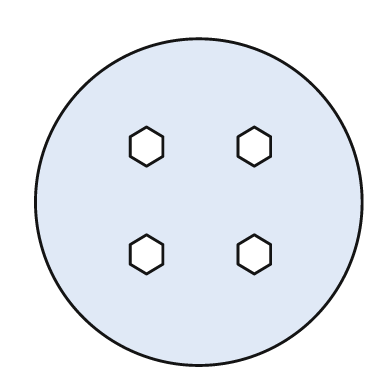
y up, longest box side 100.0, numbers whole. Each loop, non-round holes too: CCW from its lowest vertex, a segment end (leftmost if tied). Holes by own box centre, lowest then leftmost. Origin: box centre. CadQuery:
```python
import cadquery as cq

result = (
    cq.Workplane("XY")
    .moveTo(0.0, 0.0)
    .circle(50.0)
    .moveTo(-16.0, -22.0)
    .lineTo(-11.0, -19.0)
    .lineTo(-11.0, -13.0)
    .lineTo(-16.0, -10.0)
    .lineTo(-21.0, -13.0)
    .lineTo(-21.0, -19.0)
    .close()
    .moveTo(17.0, -22.0)
    .lineTo(22.0, -19.0)
    .lineTo(22.0, -13.0)
    .lineTo(17.0, -10.0)
    .lineTo(12.0, -13.0)
    .lineTo(12.0, -19.0)
    .close()
    .moveTo(-16.0, 11.0)
    .lineTo(-11.0, 14.0)
    .lineTo(-11.0, 20.0)
    .lineTo(-16.0, 23.0)
    .lineTo(-21.0, 20.0)
    .lineTo(-21.0, 14.0)
    .close()
    .moveTo(17.0, 11.0)
    .lineTo(22.0, 14.0)
    .lineTo(22.0, 20.0)
    .lineTo(17.0, 23.0)
    .lineTo(12.0, 20.0)
    .lineTo(12.0, 14.0)
    .close()
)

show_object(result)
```